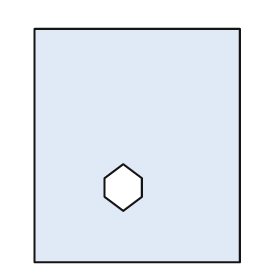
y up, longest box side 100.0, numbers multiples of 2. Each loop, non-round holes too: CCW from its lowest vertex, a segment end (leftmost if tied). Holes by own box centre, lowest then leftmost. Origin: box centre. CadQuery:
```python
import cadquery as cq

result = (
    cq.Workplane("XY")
    .moveTo(-44.0, -50.0)
    .lineTo(44.0, -50.0)
    .lineTo(44.0, 50.0)
    .lineTo(-44.0, 50.0)
    .close()
    .moveTo(-6.0, -28.0)
    .lineTo(2.0, -22.0)
    .lineTo(2.0, -14.0)
    .lineTo(-6.0, -8.0)
    .lineTo(-14.0, -14.0)
    .lineTo(-14.0, -22.0)
    .close()
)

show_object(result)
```